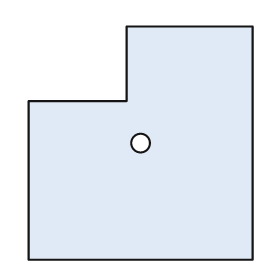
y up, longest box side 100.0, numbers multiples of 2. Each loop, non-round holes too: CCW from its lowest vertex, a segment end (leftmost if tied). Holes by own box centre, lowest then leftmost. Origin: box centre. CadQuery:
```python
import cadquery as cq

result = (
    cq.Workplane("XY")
    .moveTo(-48.0, -50.0)
    .lineTo(48.0, -50.0)
    .lineTo(48.0, 50.0)
    .lineTo(-6.0, 50.0)
    .lineTo(-6.0, 18.0)
    .lineTo(-48.0, 18.0)
    .close()
    .moveTo(0.0, 0.0)
    .circle(4.0)
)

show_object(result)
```